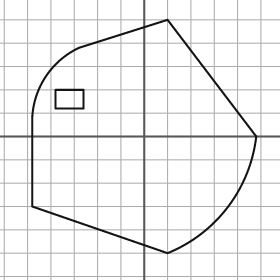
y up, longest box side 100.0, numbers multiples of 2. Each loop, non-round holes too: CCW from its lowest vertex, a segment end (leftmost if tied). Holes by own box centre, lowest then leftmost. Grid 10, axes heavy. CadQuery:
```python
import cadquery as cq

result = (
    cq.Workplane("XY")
    .moveTo(10.0, -50.0)
    .threePointArc((36.0, -30.0), (48.0, 0.0))
    .lineTo(10.0, 50.0)
    .lineTo(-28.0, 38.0)
    .threePointArc((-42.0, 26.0), (-48.0, 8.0))
    .lineTo(-48.0, -30.0)
    .close()
    .moveTo(-38.0, 12.0)
    .lineTo(-26.0, 12.0)
    .lineTo(-26.0, 20.0)
    .lineTo(-38.0, 20.0)
    .close()
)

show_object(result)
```